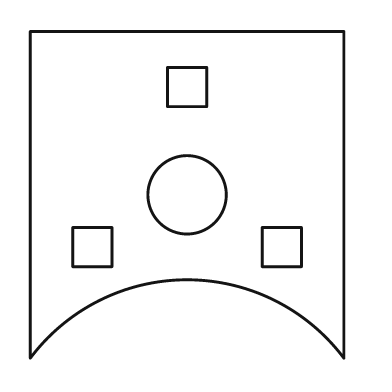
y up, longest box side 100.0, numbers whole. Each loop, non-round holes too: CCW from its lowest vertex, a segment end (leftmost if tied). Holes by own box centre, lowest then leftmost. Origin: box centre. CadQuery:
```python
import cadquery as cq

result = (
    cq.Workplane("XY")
    .moveTo(-48.0, -50.0)
    .threePointArc((0.0, -26.0), (48.0, -50.0))
    .lineTo(48.0, 50.0)
    .lineTo(-48.0, 50.0)
    .close()
    .moveTo(-35.0, -22.0)
    .lineTo(-23.0, -22.0)
    .lineTo(-23.0, -10.0)
    .lineTo(-35.0, -10.0)
    .close()
    .moveTo(23.0, -22.0)
    .lineTo(35.0, -22.0)
    .lineTo(35.0, -10.0)
    .lineTo(23.0, -10.0)
    .close()
    .moveTo(0.0, 0.0)
    .circle(12.0)
    .moveTo(-6.0, 27.0)
    .lineTo(6.0, 27.0)
    .lineTo(6.0, 39.0)
    .lineTo(-6.0, 39.0)
    .close()
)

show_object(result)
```